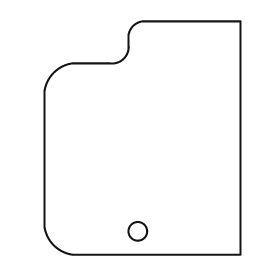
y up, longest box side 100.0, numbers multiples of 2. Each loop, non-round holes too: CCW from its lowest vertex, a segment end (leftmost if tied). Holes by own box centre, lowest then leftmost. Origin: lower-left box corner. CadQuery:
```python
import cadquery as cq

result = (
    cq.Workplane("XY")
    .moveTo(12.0, 0.0)
    .lineTo(84.0, 0.0)
    .lineTo(84.0, 100.0)
    .lineTo(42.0, 100.0)
    .threePointArc((38.0, 98.0), (36.0, 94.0))
    .lineTo(36.0, 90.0)
    .threePointArc((34.0, 84.0), (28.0, 82.0))
    .lineTo(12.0, 82.0)
    .threePointArc((4.0, 78.0), (0.0, 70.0))
    .lineTo(0.0, 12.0)
    .threePointArc((4.0, 4.0), (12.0, 0.0))
    .close()
    .moveTo(40.0, 10.0)
    .circle(4.0)
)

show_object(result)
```